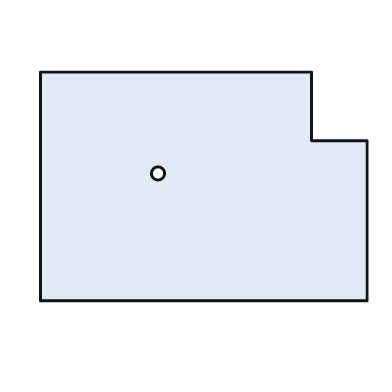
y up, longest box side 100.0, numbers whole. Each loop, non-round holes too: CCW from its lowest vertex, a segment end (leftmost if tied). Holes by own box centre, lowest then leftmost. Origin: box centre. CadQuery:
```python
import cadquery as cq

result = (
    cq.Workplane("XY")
    .moveTo(-50.0, -35.0)
    .lineTo(50.0, -35.0)
    .lineTo(50.0, 14.0)
    .lineTo(33.0, 14.0)
    .lineTo(33.0, 35.0)
    .lineTo(-50.0, 35.0)
    .close()
    .moveTo(-14.0, 4.0)
    .circle(2.0)
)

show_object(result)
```